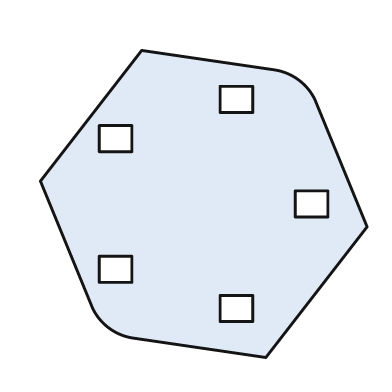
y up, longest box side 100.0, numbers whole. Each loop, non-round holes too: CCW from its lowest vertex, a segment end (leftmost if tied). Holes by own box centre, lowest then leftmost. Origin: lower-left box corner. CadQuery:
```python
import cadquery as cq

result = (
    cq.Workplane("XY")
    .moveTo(69.0, 0.0)
    .lineTo(100.0, 40.0)
    .lineTo(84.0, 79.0)
    .threePointArc((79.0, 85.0), (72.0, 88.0))
    .lineTo(31.0, 94.0)
    .lineTo(0.0, 54.0)
    .lineTo(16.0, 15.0)
    .threePointArc((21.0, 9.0), (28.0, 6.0))
    .close()
    .moveTo(55.0, 11.0)
    .lineTo(65.0, 11.0)
    .lineTo(65.0, 19.0)
    .lineTo(55.0, 19.0)
    .close()
    .moveTo(18.0, 23.0)
    .lineTo(28.0, 23.0)
    .lineTo(28.0, 31.0)
    .lineTo(18.0, 31.0)
    .close()
    .moveTo(78.0, 43.0)
    .lineTo(88.0, 43.0)
    .lineTo(88.0, 51.0)
    .lineTo(78.0, 51.0)
    .close()
    .moveTo(18.0, 63.0)
    .lineTo(28.0, 63.0)
    .lineTo(28.0, 71.0)
    .lineTo(18.0, 71.0)
    .close()
    .moveTo(55.0, 75.0)
    .lineTo(65.0, 75.0)
    .lineTo(65.0, 83.0)
    .lineTo(55.0, 83.0)
    .close()
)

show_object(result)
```